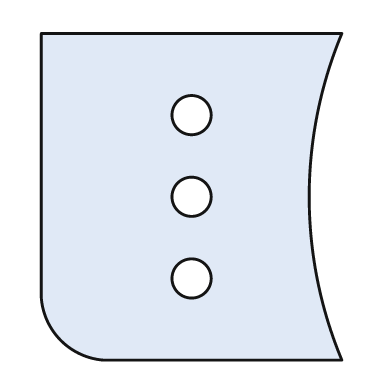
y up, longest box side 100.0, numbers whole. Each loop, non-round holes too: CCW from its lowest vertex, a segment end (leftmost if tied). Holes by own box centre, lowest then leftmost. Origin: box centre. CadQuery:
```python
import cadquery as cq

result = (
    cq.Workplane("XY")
    .moveTo(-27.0, -50.0)
    .lineTo(46.0, -50.0)
    .threePointArc((36.0, 0.0), (46.0, 50.0))
    .lineTo(-46.0, 50.0)
    .lineTo(-46.0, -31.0)
    .threePointArc((-40.0, -44.0), (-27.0, -50.0))
    .close()
    .moveTo(0.0, -25.0)
    .circle(6.0)
    .moveTo(0.0, 0.0)
    .circle(6.0)
    .moveTo(0.0, 25.0)
    .circle(6.0)
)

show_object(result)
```